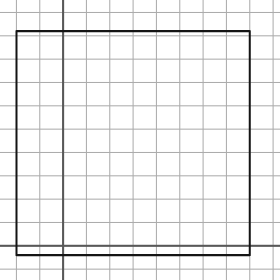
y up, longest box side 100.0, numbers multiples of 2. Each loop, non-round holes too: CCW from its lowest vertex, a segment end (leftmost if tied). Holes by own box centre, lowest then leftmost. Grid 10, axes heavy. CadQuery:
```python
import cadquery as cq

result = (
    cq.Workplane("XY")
    .moveTo(-20.0, -4.0)
    .lineTo(80.0, -4.0)
    .lineTo(80.0, 92.0)
    .lineTo(-20.0, 92.0)
    .close()
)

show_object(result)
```